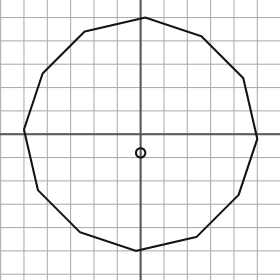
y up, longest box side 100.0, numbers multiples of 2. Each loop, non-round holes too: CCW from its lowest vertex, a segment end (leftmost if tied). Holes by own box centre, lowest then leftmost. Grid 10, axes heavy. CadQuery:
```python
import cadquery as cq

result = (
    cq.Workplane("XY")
    .moveTo(-2.0, -50.0)
    .lineTo(24.0, -44.0)
    .lineTo(42.0, -26.0)
    .lineTo(50.0, -2.0)
    .lineTo(44.0, 24.0)
    .lineTo(26.0, 42.0)
    .lineTo(2.0, 50.0)
    .lineTo(-24.0, 44.0)
    .lineTo(-42.0, 26.0)
    .lineTo(-50.0, 2.0)
    .lineTo(-44.0, -24.0)
    .lineTo(-26.0, -42.0)
    .close()
    .moveTo(0.0, -8.0)
    .circle(2.0)
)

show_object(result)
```